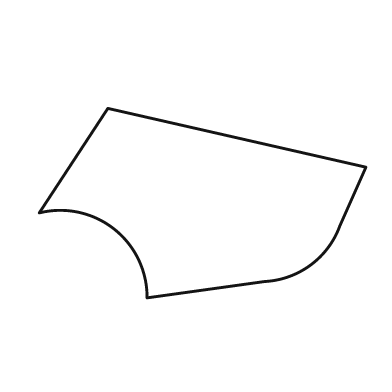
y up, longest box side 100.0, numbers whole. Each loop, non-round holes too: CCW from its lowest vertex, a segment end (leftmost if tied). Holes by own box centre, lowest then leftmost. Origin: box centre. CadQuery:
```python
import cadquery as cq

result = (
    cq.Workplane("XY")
    .moveTo(-17.0, -29.0)
    .lineTo(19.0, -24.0)
    .threePointArc((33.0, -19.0), (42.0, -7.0))
    .lineTo(50.0, 11.0)
    .lineTo(-29.0, 29.0)
    .lineTo(-50.0, -3.0)
    .threePointArc((-27.0, -8.0), (-17.0, -29.0))
    .close()
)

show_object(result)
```